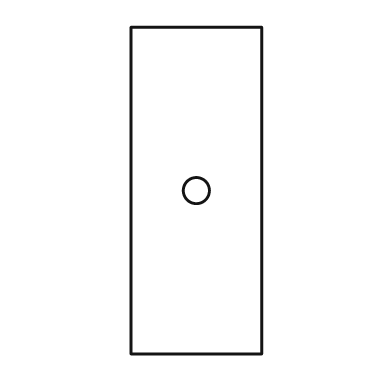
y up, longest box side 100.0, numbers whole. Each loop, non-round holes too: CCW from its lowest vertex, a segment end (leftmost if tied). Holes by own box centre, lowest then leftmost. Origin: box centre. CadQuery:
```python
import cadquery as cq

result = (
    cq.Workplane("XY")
    .moveTo(-20.0, -50.0)
    .lineTo(20.0, -50.0)
    .lineTo(20.0, 50.0)
    .lineTo(-20.0, 50.0)
    .close()
    .moveTo(0.0, 0.0)
    .circle(4.0)
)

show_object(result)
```